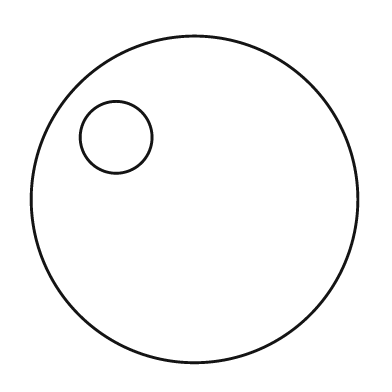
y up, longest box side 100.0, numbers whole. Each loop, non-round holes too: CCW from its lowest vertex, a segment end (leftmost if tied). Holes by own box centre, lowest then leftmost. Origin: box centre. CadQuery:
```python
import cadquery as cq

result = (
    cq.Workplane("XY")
    .moveTo(0.0, 0.0)
    .circle(50.0)
    .moveTo(-24.0, 19.0)
    .circle(11.0)
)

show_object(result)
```